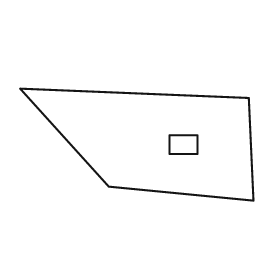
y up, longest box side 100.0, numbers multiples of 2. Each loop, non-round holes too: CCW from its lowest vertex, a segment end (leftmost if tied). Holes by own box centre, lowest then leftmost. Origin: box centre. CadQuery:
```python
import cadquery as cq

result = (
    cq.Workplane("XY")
    .moveTo(50.0, -24.0)
    .lineTo(48.0, 20.0)
    .lineTo(-50.0, 24.0)
    .lineTo(-12.0, -18.0)
    .close()
    .moveTo(14.0, -4.0)
    .lineTo(26.0, -4.0)
    .lineTo(26.0, 4.0)
    .lineTo(14.0, 4.0)
    .close()
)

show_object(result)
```